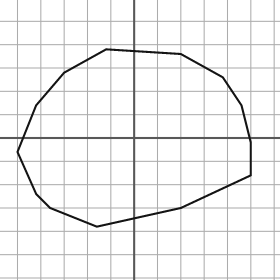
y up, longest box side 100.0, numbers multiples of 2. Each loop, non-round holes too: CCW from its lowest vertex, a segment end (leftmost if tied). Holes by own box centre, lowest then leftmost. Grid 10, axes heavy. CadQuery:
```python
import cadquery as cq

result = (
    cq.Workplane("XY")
    .moveTo(-16.0, -38.0)
    .lineTo(20.0, -30.0)
    .lineTo(50.0, -16.0)
    .lineTo(50.0, -2.0)
    .lineTo(46.0, 14.0)
    .lineTo(38.0, 26.0)
    .lineTo(20.0, 36.0)
    .lineTo(-12.0, 38.0)
    .lineTo(-30.0, 28.0)
    .lineTo(-42.0, 14.0)
    .lineTo(-50.0, -6.0)
    .lineTo(-42.0, -24.0)
    .lineTo(-36.0, -30.0)
    .close()
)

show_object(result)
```